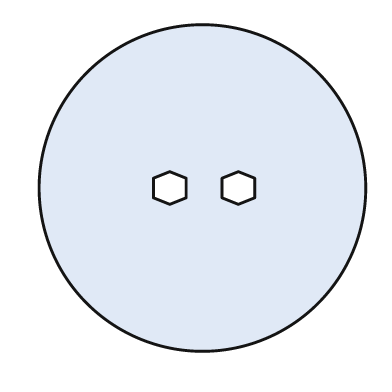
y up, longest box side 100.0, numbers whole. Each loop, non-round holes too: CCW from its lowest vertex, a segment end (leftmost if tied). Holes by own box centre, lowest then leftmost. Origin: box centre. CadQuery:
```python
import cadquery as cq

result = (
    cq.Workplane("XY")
    .moveTo(0.0, 0.0)
    .circle(50.0)
    .moveTo(-10.0, -5.0)
    .lineTo(-5.0, -3.0)
    .lineTo(-5.0, 3.0)
    .lineTo(-10.0, 5.0)
    .lineTo(-15.0, 3.0)
    .lineTo(-15.0, -3.0)
    .close()
    .moveTo(11.0, -5.0)
    .lineTo(16.0, -3.0)
    .lineTo(16.0, 3.0)
    .lineTo(11.0, 5.0)
    .lineTo(6.0, 3.0)
    .lineTo(6.0, -3.0)
    .close()
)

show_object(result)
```